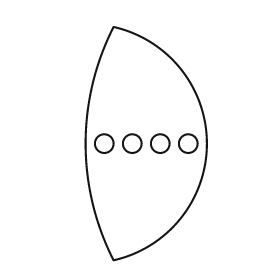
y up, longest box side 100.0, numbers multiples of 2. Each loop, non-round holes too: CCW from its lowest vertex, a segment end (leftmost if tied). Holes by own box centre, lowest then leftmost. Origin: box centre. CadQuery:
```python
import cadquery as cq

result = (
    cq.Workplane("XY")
    .moveTo(-14.0, -50.0)
    .threePointArc((26.0, 0.0), (-14.0, 50.0))
    .threePointArc((-26.0, 0.0), (-14.0, -50.0))
    .close()
    .moveTo(-18.0, 0.0)
    .circle(4.0)
    .moveTo(-6.0, 0.0)
    .circle(4.0)
    .moveTo(6.0, 0.0)
    .circle(4.0)
    .moveTo(18.0, 0.0)
    .circle(4.0)
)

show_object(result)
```